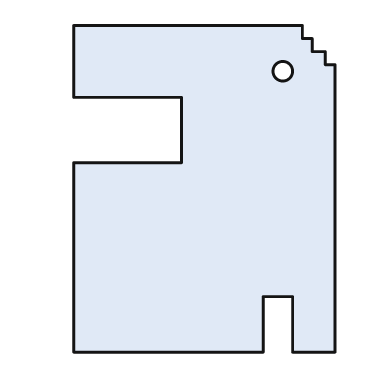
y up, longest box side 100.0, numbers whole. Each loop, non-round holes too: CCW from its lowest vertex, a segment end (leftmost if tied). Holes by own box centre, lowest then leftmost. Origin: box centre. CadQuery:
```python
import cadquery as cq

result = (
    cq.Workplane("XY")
    .moveTo(-40.0, -50.0)
    .lineTo(18.0, -50.0)
    .lineTo(18.0, -33.0)
    .lineTo(27.0, -33.0)
    .lineTo(27.0, -50.0)
    .lineTo(40.0, -50.0)
    .lineTo(40.0, 38.0)
    .lineTo(37.0, 38.0)
    .lineTo(37.0, 42.0)
    .lineTo(33.0, 42.0)
    .lineTo(33.0, 46.0)
    .lineTo(30.0, 46.0)
    .lineTo(30.0, 50.0)
    .lineTo(-40.0, 50.0)
    .lineTo(-40.0, 28.0)
    .lineTo(-7.0, 28.0)
    .lineTo(-7.0, 8.0)
    .lineTo(-40.0, 8.0)
    .close()
    .moveTo(24.0, 36.0)
    .circle(3.0)
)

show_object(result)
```